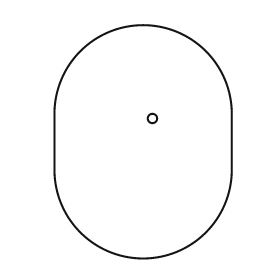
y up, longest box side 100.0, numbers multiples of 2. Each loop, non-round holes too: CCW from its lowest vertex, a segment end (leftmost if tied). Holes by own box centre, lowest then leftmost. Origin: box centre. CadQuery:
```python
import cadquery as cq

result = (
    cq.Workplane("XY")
    .moveTo(-38.0, -12.0)
    .threePointArc((0.0, -50.0), (38.0, -12.0))
    .lineTo(38.0, 12.0)
    .threePointArc((0.0, 50.0), (-38.0, 12.0))
    .close()
    .moveTo(4.0, 10.0)
    .circle(2.0)
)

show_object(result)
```